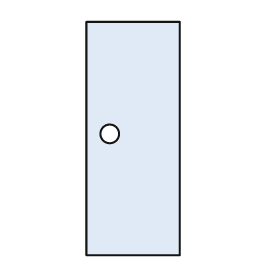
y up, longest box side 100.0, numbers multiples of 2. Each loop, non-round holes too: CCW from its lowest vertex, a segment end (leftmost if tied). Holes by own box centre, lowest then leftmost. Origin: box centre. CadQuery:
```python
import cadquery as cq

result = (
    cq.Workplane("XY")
    .moveTo(-20.0, -50.0)
    .lineTo(20.0, -50.0)
    .lineTo(20.0, 50.0)
    .lineTo(-20.0, 50.0)
    .close()
    .moveTo(-10.0, 2.0)
    .circle(4.0)
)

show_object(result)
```